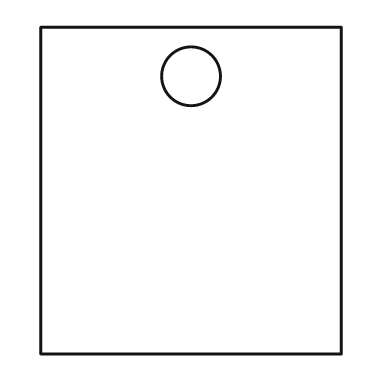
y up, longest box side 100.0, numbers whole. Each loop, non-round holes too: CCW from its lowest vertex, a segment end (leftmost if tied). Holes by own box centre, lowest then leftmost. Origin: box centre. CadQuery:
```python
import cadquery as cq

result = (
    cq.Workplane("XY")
    .moveTo(-46.0, -50.0)
    .lineTo(46.0, -50.0)
    .lineTo(46.0, 50.0)
    .lineTo(-46.0, 50.0)
    .close()
    .moveTo(0.0, 35.0)
    .circle(9.0)
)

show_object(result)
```